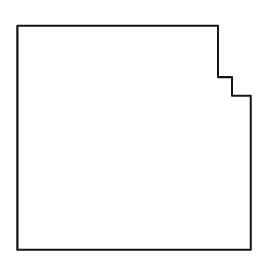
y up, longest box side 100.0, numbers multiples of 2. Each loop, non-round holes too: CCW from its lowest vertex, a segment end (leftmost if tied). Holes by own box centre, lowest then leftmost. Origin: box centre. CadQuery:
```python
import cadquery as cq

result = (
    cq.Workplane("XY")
    .moveTo(-50.0, -48.0)
    .lineTo(50.0, -48.0)
    .lineTo(50.0, 18.0)
    .lineTo(42.0, 18.0)
    .lineTo(42.0, 26.0)
    .lineTo(36.0, 26.0)
    .lineTo(36.0, 48.0)
    .lineTo(-50.0, 48.0)
    .close()
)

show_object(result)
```